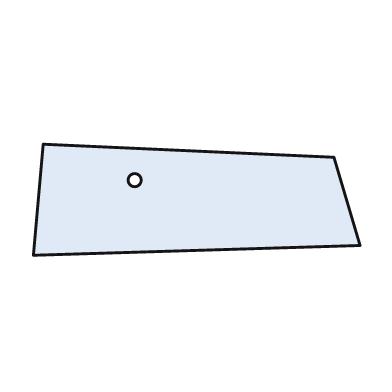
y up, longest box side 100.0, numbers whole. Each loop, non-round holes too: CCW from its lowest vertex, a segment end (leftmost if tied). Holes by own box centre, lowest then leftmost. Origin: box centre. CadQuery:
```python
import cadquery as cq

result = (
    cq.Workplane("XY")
    .moveTo(-50.0, -17.0)
    .lineTo(50.0, -14.0)
    .lineTo(42.0, 13.0)
    .lineTo(-47.0, 17.0)
    .close()
    .moveTo(-19.0, 6.0)
    .circle(2.0)
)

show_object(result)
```